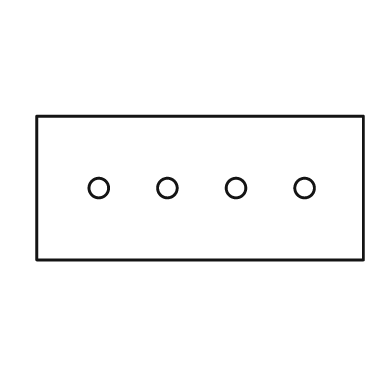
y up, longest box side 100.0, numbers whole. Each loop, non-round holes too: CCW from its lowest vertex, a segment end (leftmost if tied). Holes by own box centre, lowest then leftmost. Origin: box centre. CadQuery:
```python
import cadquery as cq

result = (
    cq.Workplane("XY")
    .moveTo(-50.0, -22.0)
    .lineTo(50.0, -22.0)
    .lineTo(50.0, 22.0)
    .lineTo(-50.0, 22.0)
    .close()
    .moveTo(-31.0, 0.0)
    .circle(3.0)
    .moveTo(-10.0, 0.0)
    .circle(3.0)
    .moveTo(11.0, 0.0)
    .circle(3.0)
    .moveTo(32.0, 0.0)
    .circle(3.0)
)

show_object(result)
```